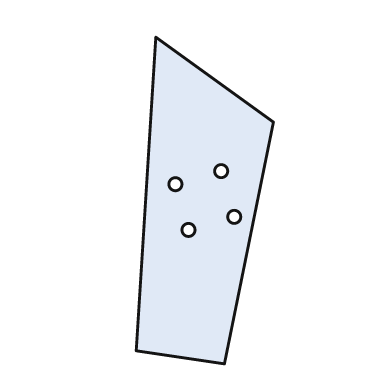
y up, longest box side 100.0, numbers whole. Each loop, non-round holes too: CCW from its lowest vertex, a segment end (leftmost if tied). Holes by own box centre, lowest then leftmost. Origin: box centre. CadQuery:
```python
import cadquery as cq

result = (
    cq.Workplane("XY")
    .moveTo(6.0, -50.0)
    .lineTo(21.0, 24.0)
    .lineTo(-15.0, 50.0)
    .lineTo(-21.0, -46.0)
    .close()
    .moveTo(-5.0, -9.0)
    .circle(2.0)
    .moveTo(9.0, -5.0)
    .circle(2.0)
    .moveTo(-9.0, 5.0)
    .circle(2.0)
    .moveTo(5.0, 9.0)
    .circle(2.0)
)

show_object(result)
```